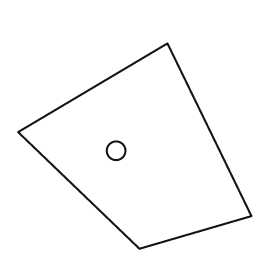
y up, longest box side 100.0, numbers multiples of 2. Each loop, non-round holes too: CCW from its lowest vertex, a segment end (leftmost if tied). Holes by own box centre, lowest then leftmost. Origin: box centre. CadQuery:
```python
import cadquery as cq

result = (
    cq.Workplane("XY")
    .moveTo(2.0, -44.0)
    .lineTo(50.0, -30.0)
    .lineTo(14.0, 44.0)
    .lineTo(-50.0, 6.0)
    .close()
    .moveTo(-8.0, -2.0)
    .circle(4.0)
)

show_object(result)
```